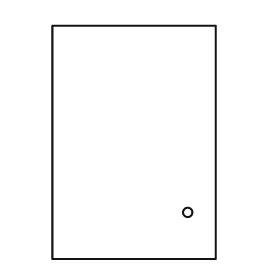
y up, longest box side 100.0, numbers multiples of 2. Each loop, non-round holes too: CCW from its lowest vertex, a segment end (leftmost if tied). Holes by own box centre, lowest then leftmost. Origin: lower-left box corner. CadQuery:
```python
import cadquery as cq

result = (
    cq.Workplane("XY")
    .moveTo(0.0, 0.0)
    .lineTo(70.0, 0.0)
    .lineTo(70.0, 100.0)
    .lineTo(0.0, 100.0)
    .close()
    .moveTo(58.0, 20.0)
    .circle(2.0)
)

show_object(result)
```